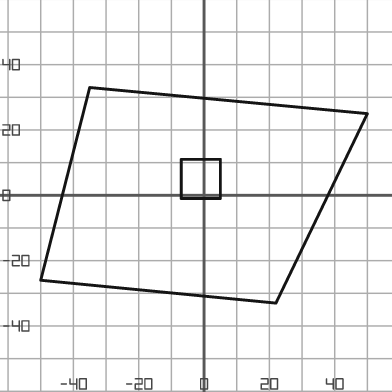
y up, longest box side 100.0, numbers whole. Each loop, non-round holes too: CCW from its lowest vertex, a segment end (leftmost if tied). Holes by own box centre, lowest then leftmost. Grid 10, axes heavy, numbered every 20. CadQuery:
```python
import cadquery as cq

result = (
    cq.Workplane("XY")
    .moveTo(22.0, -33.0)
    .lineTo(50.0, 25.0)
    .lineTo(-35.0, 33.0)
    .lineTo(-50.0, -26.0)
    .close()
    .moveTo(-7.0, -1.0)
    .lineTo(5.0, -1.0)
    .lineTo(5.0, 11.0)
    .lineTo(-7.0, 11.0)
    .close()
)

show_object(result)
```